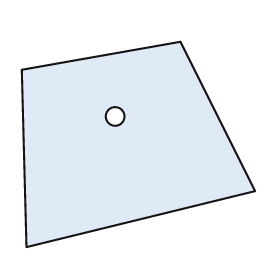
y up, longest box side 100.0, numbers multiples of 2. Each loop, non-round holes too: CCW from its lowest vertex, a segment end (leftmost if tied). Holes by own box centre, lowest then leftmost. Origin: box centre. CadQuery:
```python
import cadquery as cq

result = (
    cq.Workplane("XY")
    .moveTo(-48.0, -44.0)
    .lineTo(50.0, -20.0)
    .lineTo(18.0, 44.0)
    .lineTo(-50.0, 32.0)
    .close()
    .moveTo(-10.0, 12.0)
    .circle(4.0)
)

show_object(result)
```